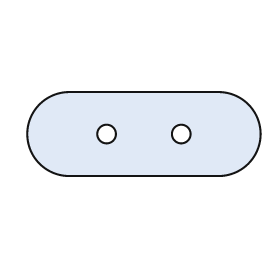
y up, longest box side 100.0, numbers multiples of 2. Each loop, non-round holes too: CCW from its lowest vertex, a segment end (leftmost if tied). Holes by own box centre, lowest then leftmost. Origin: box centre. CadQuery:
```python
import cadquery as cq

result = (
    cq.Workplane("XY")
    .moveTo(-32.0, -18.0)
    .lineTo(32.0, -18.0)
    .threePointArc((50.0, 0.0), (32.0, 18.0))
    .lineTo(-32.0, 18.0)
    .threePointArc((-50.0, 0.0), (-32.0, -18.0))
    .close()
    .moveTo(-16.0, 0.0)
    .circle(4.0)
    .moveTo(16.0, 0.0)
    .circle(4.0)
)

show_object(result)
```